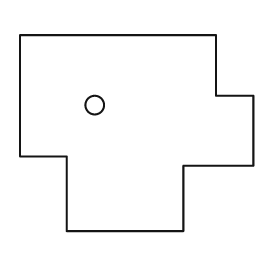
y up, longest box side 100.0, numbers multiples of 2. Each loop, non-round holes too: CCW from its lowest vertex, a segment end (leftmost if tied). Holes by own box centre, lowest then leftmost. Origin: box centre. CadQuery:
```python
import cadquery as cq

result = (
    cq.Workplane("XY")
    .moveTo(-30.0, -42.0)
    .lineTo(20.0, -42.0)
    .lineTo(20.0, -14.0)
    .lineTo(50.0, -14.0)
    .lineTo(50.0, 16.0)
    .lineTo(34.0, 16.0)
    .lineTo(34.0, 42.0)
    .lineTo(-50.0, 42.0)
    .lineTo(-50.0, -10.0)
    .lineTo(-30.0, -10.0)
    .close()
    .moveTo(-18.0, 12.0)
    .circle(4.0)
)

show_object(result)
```